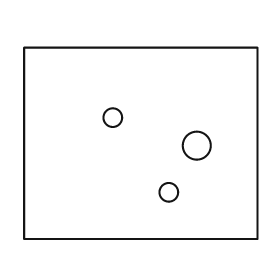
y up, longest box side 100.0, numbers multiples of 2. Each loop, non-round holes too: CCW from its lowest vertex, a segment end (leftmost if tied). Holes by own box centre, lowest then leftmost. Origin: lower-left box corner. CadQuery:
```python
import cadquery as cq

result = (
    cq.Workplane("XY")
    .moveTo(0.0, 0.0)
    .lineTo(100.0, 0.0)
    .lineTo(100.0, 82.0)
    .lineTo(0.0, 82.0)
    .close()
    .moveTo(62.0, 20.0)
    .circle(4.0)
    .moveTo(74.0, 40.0)
    .circle(6.0)
    .moveTo(38.0, 52.0)
    .circle(4.0)
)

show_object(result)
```